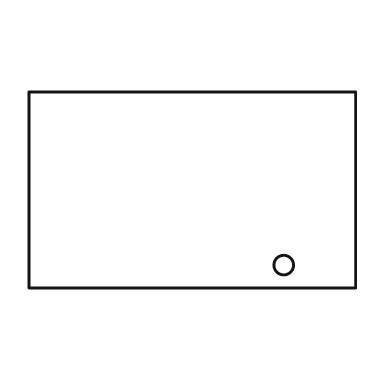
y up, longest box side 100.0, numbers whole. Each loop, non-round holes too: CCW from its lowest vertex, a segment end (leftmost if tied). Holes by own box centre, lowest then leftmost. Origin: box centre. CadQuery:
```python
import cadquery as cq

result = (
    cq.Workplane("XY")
    .moveTo(-50.0, -30.0)
    .lineTo(50.0, -30.0)
    .lineTo(50.0, 30.0)
    .lineTo(-50.0, 30.0)
    .close()
    .moveTo(28.0, -23.0)
    .circle(3.0)
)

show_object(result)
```